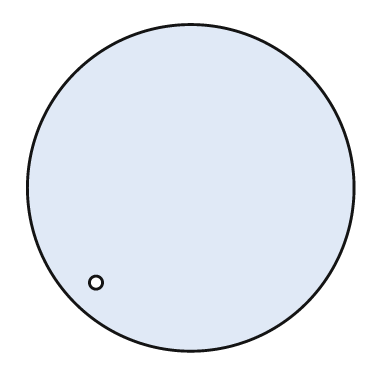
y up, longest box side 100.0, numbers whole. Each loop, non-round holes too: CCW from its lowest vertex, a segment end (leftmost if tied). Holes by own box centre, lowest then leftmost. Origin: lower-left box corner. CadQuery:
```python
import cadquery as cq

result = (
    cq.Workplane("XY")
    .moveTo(50.0, 50.0)
    .circle(50.0)
    .moveTo(21.0, 21.0)
    .circle(2.0)
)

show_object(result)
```